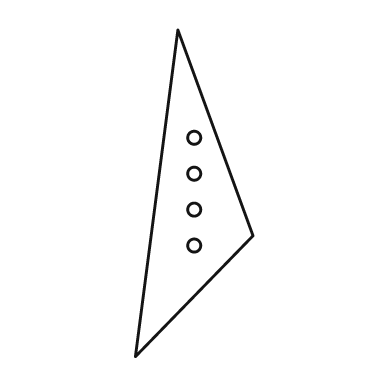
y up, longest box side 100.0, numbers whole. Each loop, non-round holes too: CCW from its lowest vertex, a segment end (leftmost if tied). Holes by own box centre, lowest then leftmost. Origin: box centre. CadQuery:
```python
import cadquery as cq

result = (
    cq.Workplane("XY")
    .moveTo(-18.0, -50.0)
    .lineTo(18.0, -13.0)
    .lineTo(-5.0, 50.0)
    .close()
    .moveTo(0.0, -16.0)
    .circle(2.0)
    .moveTo(0.0, -5.0)
    .circle(2.0)
    .moveTo(0.0, 6.0)
    .circle(2.0)
    .moveTo(0.0, 17.0)
    .circle(2.0)
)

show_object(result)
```